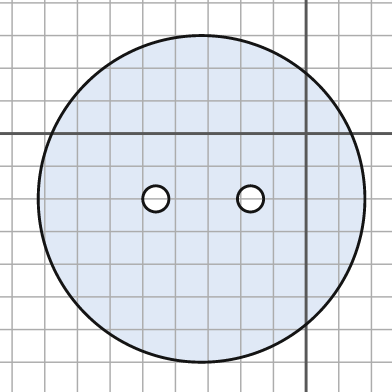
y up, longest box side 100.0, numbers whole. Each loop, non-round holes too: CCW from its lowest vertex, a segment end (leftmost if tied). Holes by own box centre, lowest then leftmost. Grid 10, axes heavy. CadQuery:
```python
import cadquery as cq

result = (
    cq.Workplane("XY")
    .moveTo(-32.0, -20.0)
    .circle(50.0)
    .moveTo(-46.0, -20.0)
    .circle(4.0)
    .moveTo(-17.0, -20.0)
    .circle(4.0)
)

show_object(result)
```